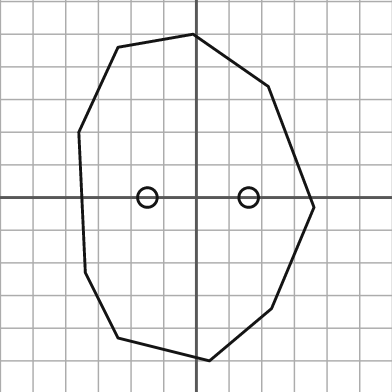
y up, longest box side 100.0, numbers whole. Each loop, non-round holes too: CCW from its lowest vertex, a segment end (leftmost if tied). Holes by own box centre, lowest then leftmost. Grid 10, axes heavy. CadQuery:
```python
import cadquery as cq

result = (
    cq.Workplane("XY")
    .moveTo(4.0, -50.0)
    .lineTo(23.0, -34.0)
    .lineTo(36.0, -3.0)
    .lineTo(22.0, 34.0)
    .lineTo(-1.0, 50.0)
    .lineTo(-24.0, 46.0)
    .lineTo(-36.0, 20.0)
    .lineTo(-34.0, -23.0)
    .lineTo(-24.0, -43.0)
    .close()
    .moveTo(-15.0, 0.0)
    .circle(3.0)
    .moveTo(16.0, 0.0)
    .circle(3.0)
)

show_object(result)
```